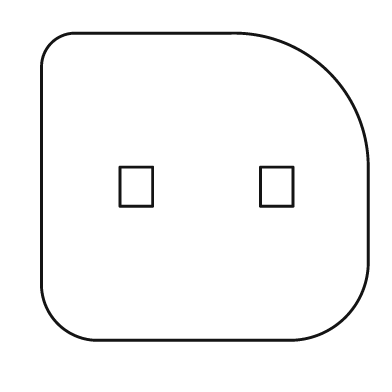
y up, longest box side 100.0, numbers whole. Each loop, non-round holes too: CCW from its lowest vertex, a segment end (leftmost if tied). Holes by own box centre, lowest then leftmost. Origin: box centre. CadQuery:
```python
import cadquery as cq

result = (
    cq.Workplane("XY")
    .moveTo(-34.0, -47.0)
    .lineTo(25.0, -47.0)
    .threePointArc((43.0, -40.0), (50.0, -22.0))
    .lineTo(50.0, 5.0)
    .threePointArc((38.0, 35.0), (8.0, 47.0))
    .lineTo(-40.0, 47.0)
    .threePointArc((-47.0, 44.0), (-50.0, 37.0))
    .lineTo(-50.0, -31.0)
    .threePointArc((-45.0, -42.0), (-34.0, -47.0))
    .close()
    .moveTo(-26.0, -6.0)
    .lineTo(-16.0, -6.0)
    .lineTo(-16.0, 6.0)
    .lineTo(-26.0, 6.0)
    .close()
    .moveTo(17.0, -6.0)
    .lineTo(27.0, -6.0)
    .lineTo(27.0, 6.0)
    .lineTo(17.0, 6.0)
    .close()
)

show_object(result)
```